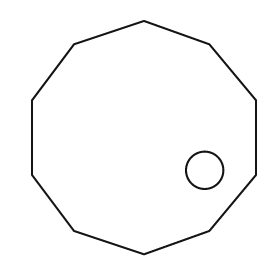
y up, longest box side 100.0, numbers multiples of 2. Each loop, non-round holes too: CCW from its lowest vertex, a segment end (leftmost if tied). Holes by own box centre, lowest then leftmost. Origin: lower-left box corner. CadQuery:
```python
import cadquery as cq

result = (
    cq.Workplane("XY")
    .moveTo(48.0, 0.0)
    .lineTo(76.0, 10.0)
    .lineTo(96.0, 34.0)
    .lineTo(96.0, 66.0)
    .lineTo(76.0, 90.0)
    .lineTo(48.0, 100.0)
    .lineTo(18.0, 90.0)
    .lineTo(0.0, 66.0)
    .lineTo(0.0, 34.0)
    .lineTo(18.0, 10.0)
    .close()
    .moveTo(74.0, 36.0)
    .circle(8.0)
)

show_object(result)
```